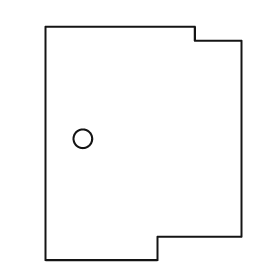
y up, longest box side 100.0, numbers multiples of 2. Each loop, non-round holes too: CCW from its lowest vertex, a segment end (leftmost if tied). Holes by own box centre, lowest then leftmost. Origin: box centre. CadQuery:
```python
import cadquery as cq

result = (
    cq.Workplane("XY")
    .moveTo(-42.0, -50.0)
    .lineTo(6.0, -50.0)
    .lineTo(6.0, -40.0)
    .lineTo(42.0, -40.0)
    .lineTo(42.0, 44.0)
    .lineTo(22.0, 44.0)
    .lineTo(22.0, 50.0)
    .lineTo(-42.0, 50.0)
    .close()
    .moveTo(-26.0, 2.0)
    .circle(4.0)
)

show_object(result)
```